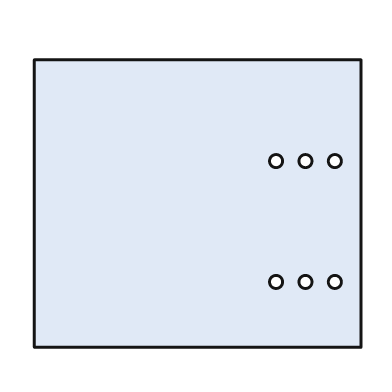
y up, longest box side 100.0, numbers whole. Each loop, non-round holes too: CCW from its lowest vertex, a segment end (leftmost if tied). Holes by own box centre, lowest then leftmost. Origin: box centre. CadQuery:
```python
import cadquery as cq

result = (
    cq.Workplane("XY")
    .moveTo(-50.0, -44.0)
    .lineTo(50.0, -44.0)
    .lineTo(50.0, 44.0)
    .lineTo(-50.0, 44.0)
    .close()
    .moveTo(24.0, -24.0)
    .circle(2.0)
    .moveTo(33.0, -24.0)
    .circle(2.0)
    .moveTo(42.0, -24.0)
    .circle(2.0)
    .moveTo(24.0, 13.0)
    .circle(2.0)
    .moveTo(33.0, 13.0)
    .circle(2.0)
    .moveTo(42.0, 13.0)
    .circle(2.0)
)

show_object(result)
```